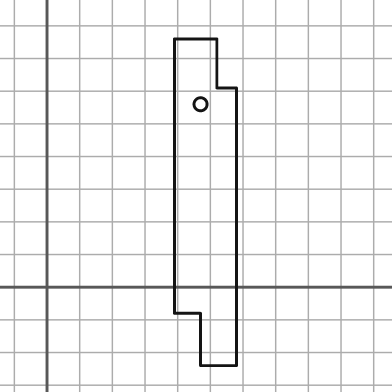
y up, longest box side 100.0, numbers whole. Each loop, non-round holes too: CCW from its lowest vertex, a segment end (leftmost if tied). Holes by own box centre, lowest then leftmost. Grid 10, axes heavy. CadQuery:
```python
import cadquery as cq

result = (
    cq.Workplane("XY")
    .moveTo(47.0, -24.0)
    .lineTo(58.0, -24.0)
    .lineTo(58.0, 61.0)
    .lineTo(52.0, 61.0)
    .lineTo(52.0, 76.0)
    .lineTo(39.0, 76.0)
    .lineTo(39.0, -8.0)
    .lineTo(47.0, -8.0)
    .close()
    .moveTo(47.0, 56.0)
    .circle(2.0)
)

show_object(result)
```